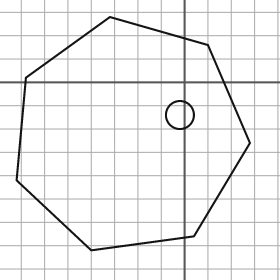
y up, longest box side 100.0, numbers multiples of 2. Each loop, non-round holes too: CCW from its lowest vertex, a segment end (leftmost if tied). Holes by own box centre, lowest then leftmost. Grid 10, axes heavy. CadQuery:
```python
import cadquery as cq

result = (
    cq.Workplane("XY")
    .moveTo(-40.0, -72.0)
    .lineTo(4.0, -66.0)
    .lineTo(28.0, -26.0)
    .lineTo(10.0, 16.0)
    .lineTo(-32.0, 28.0)
    .lineTo(-68.0, 2.0)
    .lineTo(-72.0, -42.0)
    .close()
    .moveTo(-2.0, -14.0)
    .circle(6.0)
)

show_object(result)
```